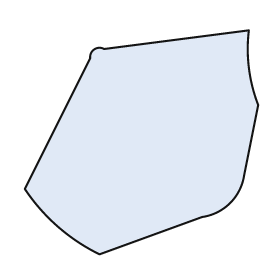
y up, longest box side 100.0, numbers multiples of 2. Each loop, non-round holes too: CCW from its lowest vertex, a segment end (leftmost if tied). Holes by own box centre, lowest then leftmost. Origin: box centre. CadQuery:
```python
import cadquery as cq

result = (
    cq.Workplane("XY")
    .moveTo(-18.0, -48.0)
    .lineTo(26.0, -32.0)
    .threePointArc((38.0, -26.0), (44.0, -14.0))
    .lineTo(50.0, 16.0)
    .threePointArc((46.0, 32.0), (46.0, 48.0))
    .lineTo(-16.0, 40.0)
    .threePointArc((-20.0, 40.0), (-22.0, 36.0))
    .lineTo(-50.0, -20.0)
    .threePointArc((-36.0, -36.0), (-18.0, -48.0))
    .close()
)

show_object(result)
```